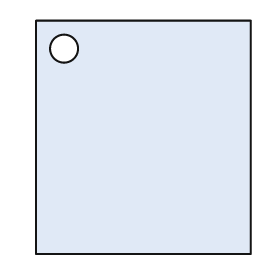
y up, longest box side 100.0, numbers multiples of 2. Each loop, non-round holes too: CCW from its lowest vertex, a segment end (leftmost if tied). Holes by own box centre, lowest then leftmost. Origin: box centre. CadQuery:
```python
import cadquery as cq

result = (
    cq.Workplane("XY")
    .moveTo(-46.0, -50.0)
    .lineTo(46.0, -50.0)
    .lineTo(46.0, 50.0)
    .lineTo(-46.0, 50.0)
    .close()
    .moveTo(-34.0, 38.0)
    .circle(6.0)
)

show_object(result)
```